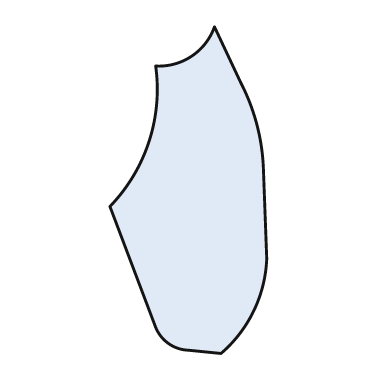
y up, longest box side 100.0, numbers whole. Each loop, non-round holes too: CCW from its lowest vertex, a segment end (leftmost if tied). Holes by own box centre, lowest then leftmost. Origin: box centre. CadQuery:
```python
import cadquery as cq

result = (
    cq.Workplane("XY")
    .moveTo(10.0, -50.0)
    .threePointArc((20.0, -37.0), (24.0, -21.0))
    .lineTo(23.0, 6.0)
    .threePointArc((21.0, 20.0), (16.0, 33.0))
    .lineTo(8.0, 50.0)
    .threePointArc((1.0, 41.0), (-10.0, 38.0))
    .threePointArc((-12.0, 15.0), (-24.0, -5.0))
    .lineTo(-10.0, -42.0)
    .threePointArc((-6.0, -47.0), (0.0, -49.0))
    .close()
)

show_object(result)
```